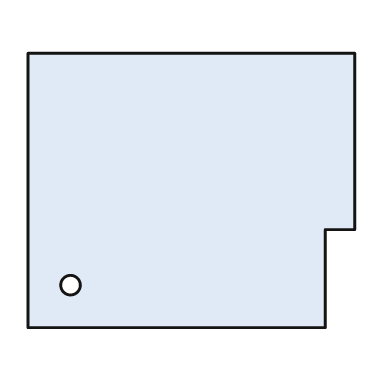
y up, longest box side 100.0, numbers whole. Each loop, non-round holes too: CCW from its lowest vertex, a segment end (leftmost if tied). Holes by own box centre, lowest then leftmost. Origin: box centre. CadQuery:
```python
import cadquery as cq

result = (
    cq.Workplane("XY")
    .moveTo(-50.0, -42.0)
    .lineTo(41.0, -42.0)
    .lineTo(41.0, -12.0)
    .lineTo(50.0, -12.0)
    .lineTo(50.0, 42.0)
    .lineTo(-50.0, 42.0)
    .close()
    .moveTo(-37.0, -29.0)
    .circle(3.0)
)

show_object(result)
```